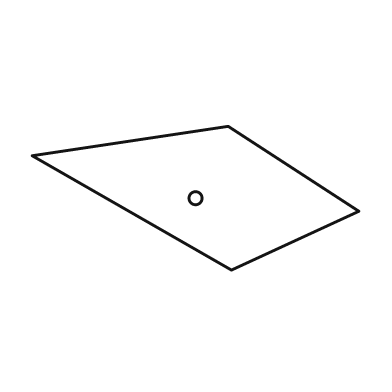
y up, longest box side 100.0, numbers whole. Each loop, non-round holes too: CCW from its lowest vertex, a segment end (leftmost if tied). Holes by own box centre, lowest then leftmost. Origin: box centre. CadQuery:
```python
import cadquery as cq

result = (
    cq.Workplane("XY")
    .moveTo(11.0, -22.0)
    .lineTo(50.0, -4.0)
    .lineTo(10.0, 22.0)
    .lineTo(-50.0, 13.0)
    .close()
    .moveTo(0.0, 0.0)
    .circle(2.0)
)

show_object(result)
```